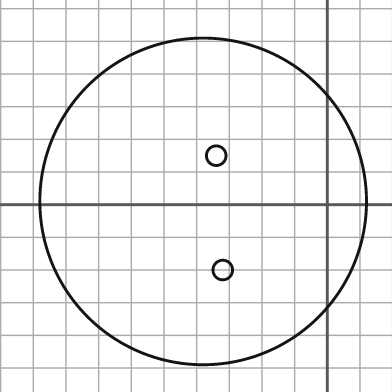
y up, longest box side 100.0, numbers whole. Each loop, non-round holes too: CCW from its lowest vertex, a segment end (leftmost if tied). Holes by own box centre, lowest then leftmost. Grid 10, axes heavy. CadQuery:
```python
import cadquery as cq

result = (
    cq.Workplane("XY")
    .moveTo(-38.0, 1.0)
    .circle(50.0)
    .moveTo(-32.0, -20.0)
    .circle(3.0)
    .moveTo(-34.0, 15.0)
    .circle(3.0)
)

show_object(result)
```